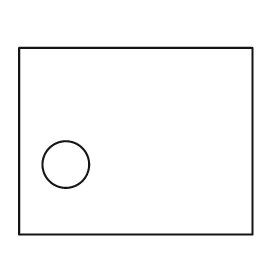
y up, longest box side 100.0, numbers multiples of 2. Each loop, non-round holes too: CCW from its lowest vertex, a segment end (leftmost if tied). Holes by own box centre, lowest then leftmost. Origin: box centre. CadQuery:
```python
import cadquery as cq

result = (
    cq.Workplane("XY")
    .moveTo(-50.0, -40.0)
    .lineTo(50.0, -40.0)
    .lineTo(50.0, 40.0)
    .lineTo(-50.0, 40.0)
    .close()
    .moveTo(-30.0, -10.0)
    .circle(10.0)
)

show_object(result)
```